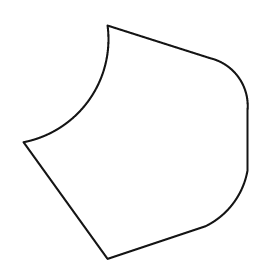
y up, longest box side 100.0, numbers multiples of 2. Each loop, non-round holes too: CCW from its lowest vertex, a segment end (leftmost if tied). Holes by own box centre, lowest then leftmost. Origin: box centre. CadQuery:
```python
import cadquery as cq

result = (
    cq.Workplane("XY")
    .moveTo(-12.0, -50.0)
    .lineTo(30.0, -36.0)
    .threePointArc((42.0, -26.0), (48.0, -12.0))
    .lineTo(48.0, 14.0)
    .threePointArc((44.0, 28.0), (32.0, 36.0))
    .lineTo(-12.0, 50.0)
    .threePointArc((-20.0, 18.0), (-48.0, 0.0))
    .close()
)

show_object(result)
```